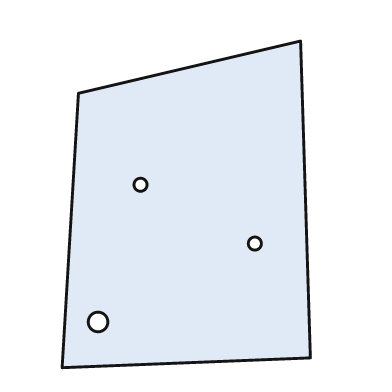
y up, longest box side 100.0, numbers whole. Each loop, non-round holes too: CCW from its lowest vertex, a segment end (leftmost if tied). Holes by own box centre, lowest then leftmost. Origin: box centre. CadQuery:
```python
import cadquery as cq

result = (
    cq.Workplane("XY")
    .moveTo(-38.0, -50.0)
    .lineTo(38.0, -47.0)
    .lineTo(35.0, 50.0)
    .lineTo(-33.0, 34.0)
    .close()
    .moveTo(-27.0, -36.0)
    .circle(3.0)
    .moveTo(21.0, -12.0)
    .circle(2.0)
    .moveTo(-14.0, 6.0)
    .circle(2.0)
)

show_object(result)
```